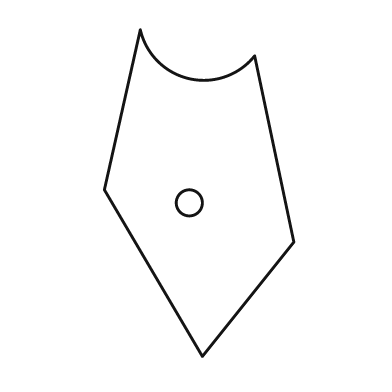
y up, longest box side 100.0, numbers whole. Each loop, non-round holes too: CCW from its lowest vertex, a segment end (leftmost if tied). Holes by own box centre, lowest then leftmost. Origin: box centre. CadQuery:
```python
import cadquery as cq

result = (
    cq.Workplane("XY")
    .moveTo(1.0, -50.0)
    .lineTo(29.0, -15.0)
    .lineTo(17.0, 42.0)
    .threePointArc((-3.0, 35.0), (-18.0, 50.0))
    .lineTo(-29.0, 1.0)
    .close()
    .moveTo(-3.0, -3.0)
    .circle(4.0)
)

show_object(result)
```